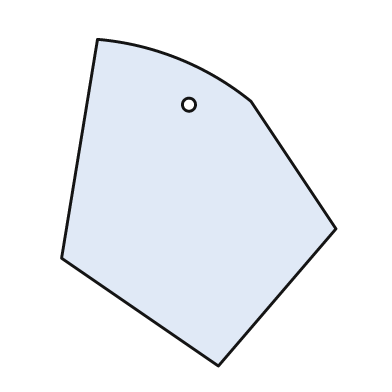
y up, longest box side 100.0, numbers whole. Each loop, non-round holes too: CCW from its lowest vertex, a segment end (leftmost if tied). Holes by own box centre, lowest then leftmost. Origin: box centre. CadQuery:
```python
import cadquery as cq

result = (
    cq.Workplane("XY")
    .moveTo(6.0, -50.0)
    .lineTo(42.0, -8.0)
    .lineTo(16.0, 31.0)
    .threePointArc((-6.0, 44.0), (-31.0, 50.0))
    .lineTo(-42.0, -17.0)
    .close()
    .moveTo(-3.0, 30.0)
    .circle(2.0)
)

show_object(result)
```